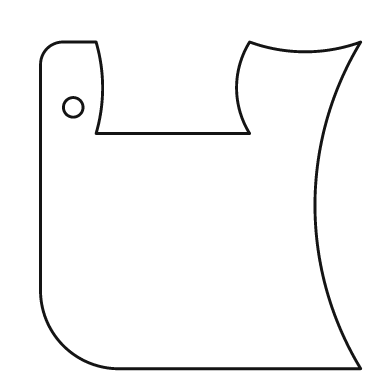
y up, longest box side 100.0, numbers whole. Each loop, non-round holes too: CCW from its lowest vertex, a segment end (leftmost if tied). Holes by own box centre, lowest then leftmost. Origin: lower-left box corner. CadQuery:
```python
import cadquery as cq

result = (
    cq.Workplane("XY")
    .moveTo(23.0, 0.0)
    .lineTo(98.0, 0.0)
    .threePointArc((84.0, 50.0), (98.0, 100.0))
    .threePointArc((81.0, 97.0), (64.0, 100.0))
    .threePointArc((60.0, 86.0), (64.0, 72.0))
    .lineTo(17.0, 72.0)
    .threePointArc((19.0, 86.0), (17.0, 100.0))
    .lineTo(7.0, 100.0)
    .threePointArc((2.0, 98.0), (0.0, 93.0))
    .lineTo(0.0, 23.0)
    .threePointArc((7.0, 7.0), (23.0, 0.0))
    .close()
    .moveTo(10.0, 80.0)
    .circle(3.0)
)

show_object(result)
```